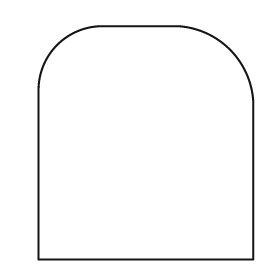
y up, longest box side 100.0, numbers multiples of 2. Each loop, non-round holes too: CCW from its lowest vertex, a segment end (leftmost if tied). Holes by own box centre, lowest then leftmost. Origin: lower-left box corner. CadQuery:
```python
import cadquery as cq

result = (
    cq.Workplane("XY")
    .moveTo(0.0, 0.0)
    .lineTo(92.0, 0.0)
    .lineTo(92.0, 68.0)
    .threePointArc((82.0, 90.0), (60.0, 100.0))
    .lineTo(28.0, 100.0)
    .threePointArc((8.0, 92.0), (0.0, 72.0))
    .close()
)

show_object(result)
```